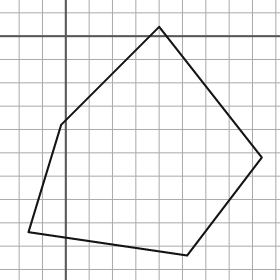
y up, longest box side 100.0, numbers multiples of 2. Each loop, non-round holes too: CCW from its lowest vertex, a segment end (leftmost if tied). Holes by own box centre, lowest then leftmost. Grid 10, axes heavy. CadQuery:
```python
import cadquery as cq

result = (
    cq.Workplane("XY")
    .moveTo(52.0, -94.0)
    .lineTo(84.0, -52.0)
    .lineTo(40.0, 4.0)
    .lineTo(-2.0, -38.0)
    .lineTo(-16.0, -84.0)
    .close()
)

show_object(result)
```